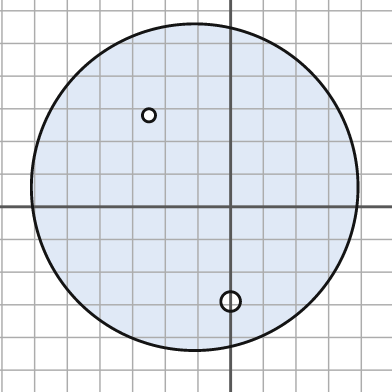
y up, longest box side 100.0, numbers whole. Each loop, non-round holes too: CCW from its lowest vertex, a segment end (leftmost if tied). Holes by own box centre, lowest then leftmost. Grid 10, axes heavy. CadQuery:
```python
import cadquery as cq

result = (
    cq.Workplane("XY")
    .moveTo(-11.0, 6.0)
    .circle(50.0)
    .moveTo(0.0, -29.0)
    .circle(3.0)
    .moveTo(-25.0, 28.0)
    .circle(2.0)
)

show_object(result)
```